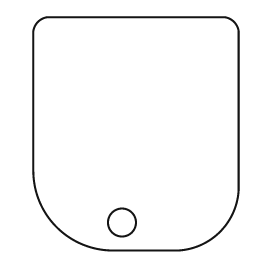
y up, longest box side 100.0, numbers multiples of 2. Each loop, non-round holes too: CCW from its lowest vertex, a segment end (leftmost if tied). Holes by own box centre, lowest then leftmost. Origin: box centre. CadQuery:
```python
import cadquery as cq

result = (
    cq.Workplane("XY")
    .moveTo(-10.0, -50.0)
    .lineTo(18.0, -50.0)
    .threePointArc((36.0, -42.0), (44.0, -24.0))
    .lineTo(44.0, 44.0)
    .threePointArc((42.0, 48.0), (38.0, 50.0))
    .lineTo(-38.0, 50.0)
    .threePointArc((-42.0, 48.0), (-44.0, 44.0))
    .lineTo(-44.0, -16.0)
    .threePointArc((-34.0, -40.0), (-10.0, -50.0))
    .close()
    .moveTo(-6.0, -38.0)
    .circle(6.0)
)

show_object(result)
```